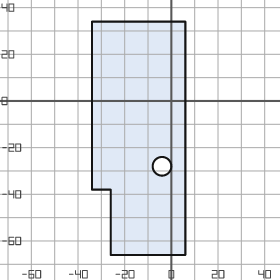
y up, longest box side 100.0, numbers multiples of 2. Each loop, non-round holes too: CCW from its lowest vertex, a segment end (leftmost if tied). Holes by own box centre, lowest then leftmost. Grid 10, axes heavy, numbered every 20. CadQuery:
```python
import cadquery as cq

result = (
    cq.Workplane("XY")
    .moveTo(-26.0, -66.0)
    .lineTo(6.0, -66.0)
    .lineTo(6.0, 34.0)
    .lineTo(-34.0, 34.0)
    .lineTo(-34.0, -38.0)
    .lineTo(-26.0, -38.0)
    .close()
    .moveTo(-4.0, -28.0)
    .circle(4.0)
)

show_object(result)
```